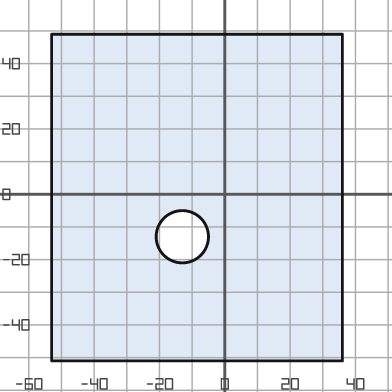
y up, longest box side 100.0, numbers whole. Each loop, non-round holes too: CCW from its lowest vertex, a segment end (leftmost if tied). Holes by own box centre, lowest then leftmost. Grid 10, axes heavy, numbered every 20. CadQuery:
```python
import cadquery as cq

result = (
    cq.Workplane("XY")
    .moveTo(-53.0, -51.0)
    .lineTo(36.0, -51.0)
    .lineTo(36.0, 49.0)
    .lineTo(-53.0, 49.0)
    .close()
    .moveTo(-13.0, -13.0)
    .circle(8.0)
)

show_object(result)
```